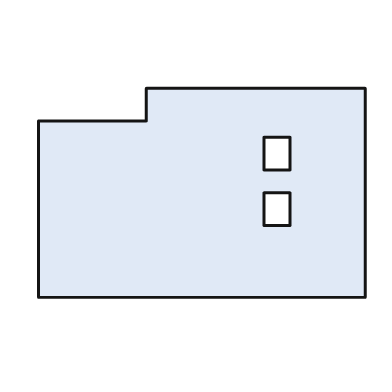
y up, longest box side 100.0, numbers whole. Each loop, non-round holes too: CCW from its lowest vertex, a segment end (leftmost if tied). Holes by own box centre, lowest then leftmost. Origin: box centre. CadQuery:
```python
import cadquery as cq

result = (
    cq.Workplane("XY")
    .moveTo(-50.0, -32.0)
    .lineTo(50.0, -32.0)
    .lineTo(50.0, 32.0)
    .lineTo(-17.0, 32.0)
    .lineTo(-17.0, 22.0)
    .lineTo(-50.0, 22.0)
    .close()
    .moveTo(19.0, -10.0)
    .lineTo(27.0, -10.0)
    .lineTo(27.0, 0.0)
    .lineTo(19.0, 0.0)
    .close()
    .moveTo(19.0, 7.0)
    .lineTo(27.0, 7.0)
    .lineTo(27.0, 17.0)
    .lineTo(19.0, 17.0)
    .close()
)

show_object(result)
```